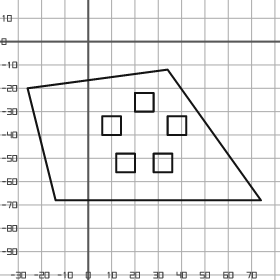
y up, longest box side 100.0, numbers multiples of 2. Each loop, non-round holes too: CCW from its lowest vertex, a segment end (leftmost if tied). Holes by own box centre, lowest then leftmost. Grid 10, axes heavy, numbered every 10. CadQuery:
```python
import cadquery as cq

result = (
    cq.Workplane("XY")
    .moveTo(-14.0, -68.0)
    .lineTo(74.0, -68.0)
    .lineTo(34.0, -12.0)
    .lineTo(-26.0, -20.0)
    .close()
    .moveTo(12.0, -56.0)
    .lineTo(20.0, -56.0)
    .lineTo(20.0, -48.0)
    .lineTo(12.0, -48.0)
    .close()
    .moveTo(28.0, -56.0)
    .lineTo(36.0, -56.0)
    .lineTo(36.0, -48.0)
    .lineTo(28.0, -48.0)
    .close()
    .moveTo(6.0, -40.0)
    .lineTo(14.0, -40.0)
    .lineTo(14.0, -32.0)
    .lineTo(6.0, -32.0)
    .close()
    .moveTo(34.0, -40.0)
    .lineTo(42.0, -40.0)
    .lineTo(42.0, -32.0)
    .lineTo(34.0, -32.0)
    .close()
    .moveTo(20.0, -30.0)
    .lineTo(28.0, -30.0)
    .lineTo(28.0, -22.0)
    .lineTo(20.0, -22.0)
    .close()
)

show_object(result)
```